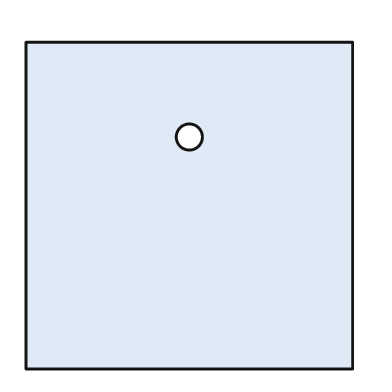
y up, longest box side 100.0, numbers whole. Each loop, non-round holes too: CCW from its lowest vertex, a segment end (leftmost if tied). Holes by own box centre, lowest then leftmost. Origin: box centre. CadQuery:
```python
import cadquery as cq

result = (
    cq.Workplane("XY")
    .moveTo(-50.0, -50.0)
    .lineTo(50.0, -50.0)
    .lineTo(50.0, 50.0)
    .lineTo(-50.0, 50.0)
    .close()
    .moveTo(0.0, 21.0)
    .circle(4.0)
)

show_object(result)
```